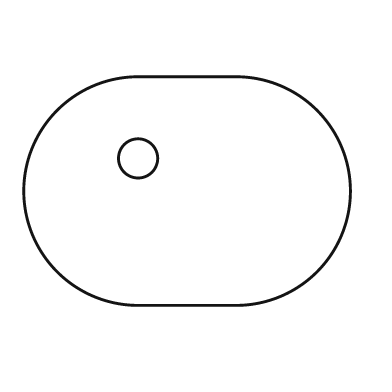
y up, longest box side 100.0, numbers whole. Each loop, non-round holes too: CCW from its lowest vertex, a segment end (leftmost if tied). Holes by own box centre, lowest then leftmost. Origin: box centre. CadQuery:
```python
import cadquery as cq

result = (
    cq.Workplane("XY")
    .moveTo(-15.0, -35.0)
    .lineTo(15.0, -35.0)
    .threePointArc((50.0, 0.0), (15.0, 35.0))
    .lineTo(-15.0, 35.0)
    .threePointArc((-50.0, 0.0), (-15.0, -35.0))
    .close()
    .moveTo(-15.0, 10.0)
    .circle(6.0)
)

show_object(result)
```